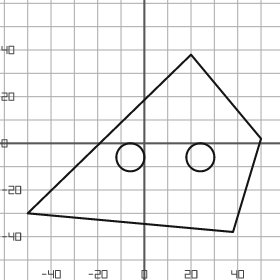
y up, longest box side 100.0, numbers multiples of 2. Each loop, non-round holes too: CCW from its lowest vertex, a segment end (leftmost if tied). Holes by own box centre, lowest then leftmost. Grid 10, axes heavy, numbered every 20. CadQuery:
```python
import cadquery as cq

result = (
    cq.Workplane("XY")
    .moveTo(38.0, -38.0)
    .lineTo(50.0, 2.0)
    .lineTo(20.0, 38.0)
    .lineTo(-50.0, -30.0)
    .close()
    .moveTo(-6.0, -6.0)
    .circle(6.0)
    .moveTo(24.0, -6.0)
    .circle(6.0)
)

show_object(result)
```